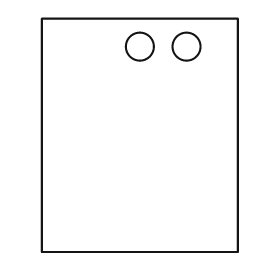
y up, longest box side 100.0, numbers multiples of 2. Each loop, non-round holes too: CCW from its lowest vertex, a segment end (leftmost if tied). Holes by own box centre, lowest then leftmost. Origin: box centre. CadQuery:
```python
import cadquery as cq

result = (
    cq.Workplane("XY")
    .moveTo(-42.0, -50.0)
    .lineTo(42.0, -50.0)
    .lineTo(42.0, 50.0)
    .lineTo(-42.0, 50.0)
    .close()
    .moveTo(0.0, 38.0)
    .circle(6.0)
    .moveTo(20.0, 38.0)
    .circle(6.0)
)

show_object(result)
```